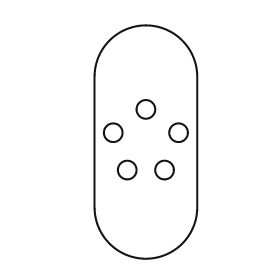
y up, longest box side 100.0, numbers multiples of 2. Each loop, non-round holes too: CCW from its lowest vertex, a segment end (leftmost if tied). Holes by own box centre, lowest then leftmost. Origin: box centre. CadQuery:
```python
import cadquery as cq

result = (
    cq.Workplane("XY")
    .moveTo(-22.0, -28.0)
    .threePointArc((0.0, -50.0), (22.0, -28.0))
    .lineTo(22.0, 28.0)
    .threePointArc((0.0, 50.0), (-22.0, 28.0))
    .close()
    .moveTo(-8.0, -12.0)
    .circle(4.0)
    .moveTo(8.0, -12.0)
    .circle(4.0)
    .moveTo(-14.0, 4.0)
    .circle(4.0)
    .moveTo(14.0, 4.0)
    .circle(4.0)
    .moveTo(0.0, 14.0)
    .circle(4.0)
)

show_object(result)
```